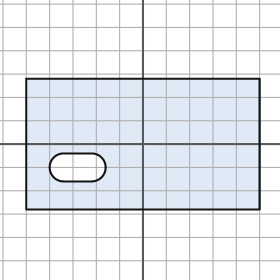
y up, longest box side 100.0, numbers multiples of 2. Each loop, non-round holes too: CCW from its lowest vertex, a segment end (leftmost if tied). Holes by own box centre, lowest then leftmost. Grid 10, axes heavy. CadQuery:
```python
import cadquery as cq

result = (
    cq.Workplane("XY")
    .moveTo(-50.0, -28.0)
    .lineTo(50.0, -28.0)
    .lineTo(50.0, 28.0)
    .lineTo(-50.0, 28.0)
    .close()
    .moveTo(-34.0, -16.0)
    .lineTo(-22.0, -16.0)
    .threePointArc((-16.0, -10.0), (-22.0, -4.0))
    .lineTo(-34.0, -4.0)
    .threePointArc((-40.0, -10.0), (-34.0, -16.0))
    .close()
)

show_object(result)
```